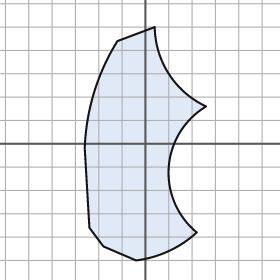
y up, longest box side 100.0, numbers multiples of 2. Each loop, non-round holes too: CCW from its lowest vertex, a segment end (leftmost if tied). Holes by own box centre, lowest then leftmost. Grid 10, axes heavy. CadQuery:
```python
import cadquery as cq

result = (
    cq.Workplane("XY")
    .moveTo(-4.0, -50.0)
    .threePointArc((10.0, -46.0), (22.0, -38.0))
    .threePointArc((10.0, -10.0), (26.0, 16.0))
    .threePointArc((10.0, 30.0), (4.0, 50.0))
    .lineTo(-12.0, 44.0)
    .threePointArc((-22.0, 22.0), (-26.0, -2.0))
    .lineTo(-24.0, -36.0)
    .lineTo(-18.0, -44.0)
    .close()
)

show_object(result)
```